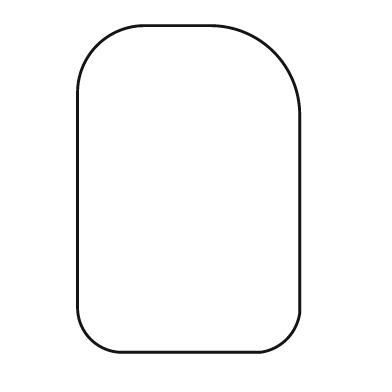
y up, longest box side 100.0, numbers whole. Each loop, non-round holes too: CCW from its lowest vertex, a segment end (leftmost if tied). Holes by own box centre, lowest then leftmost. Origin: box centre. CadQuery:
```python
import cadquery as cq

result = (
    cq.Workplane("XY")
    .moveTo(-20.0, -50.0)
    .lineTo(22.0, -50.0)
    .threePointArc((30.0, -46.0), (34.0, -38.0))
    .lineTo(34.0, 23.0)
    .threePointArc((26.0, 42.0), (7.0, 50.0))
    .lineTo(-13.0, 50.0)
    .threePointArc((-28.0, 44.0), (-34.0, 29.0))
    .lineTo(-34.0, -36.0)
    .threePointArc((-30.0, -46.0), (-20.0, -50.0))
    .close()
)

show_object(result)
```